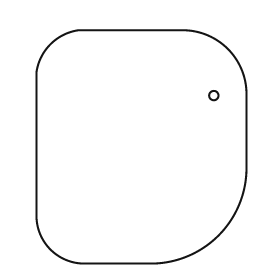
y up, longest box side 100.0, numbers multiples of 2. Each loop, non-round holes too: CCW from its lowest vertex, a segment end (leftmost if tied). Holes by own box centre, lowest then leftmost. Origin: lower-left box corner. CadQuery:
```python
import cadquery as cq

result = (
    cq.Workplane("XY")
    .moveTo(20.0, 0.0)
    .lineTo(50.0, 0.0)
    .threePointArc((78.0, 12.0), (90.0, 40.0))
    .lineTo(90.0, 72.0)
    .threePointArc((82.0, 92.0), (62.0, 100.0))
    .lineTo(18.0, 100.0)
    .threePointArc((6.0, 94.0), (0.0, 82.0))
    .lineTo(0.0, 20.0)
    .threePointArc((6.0, 6.0), (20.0, 0.0))
    .close()
    .moveTo(76.0, 72.0)
    .circle(2.0)
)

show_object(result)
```